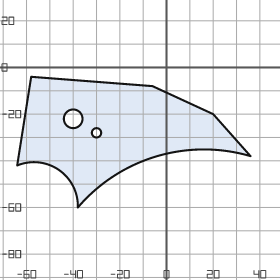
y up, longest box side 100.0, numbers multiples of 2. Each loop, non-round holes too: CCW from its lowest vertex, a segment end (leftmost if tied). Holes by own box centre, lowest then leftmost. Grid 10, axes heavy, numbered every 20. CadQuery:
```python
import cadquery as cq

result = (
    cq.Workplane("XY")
    .moveTo(-38.0, -60.0)
    .threePointArc((-4.0, -38.0), (36.0, -38.0))
    .lineTo(20.0, -20.0)
    .lineTo(-6.0, -8.0)
    .lineTo(-58.0, -4.0)
    .lineTo(-64.0, -42.0)
    .threePointArc((-46.0, -44.0), (-38.0, -60.0))
    .close()
    .moveTo(-30.0, -28.0)
    .circle(2.0)
    .moveTo(-40.0, -22.0)
    .circle(4.0)
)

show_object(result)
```